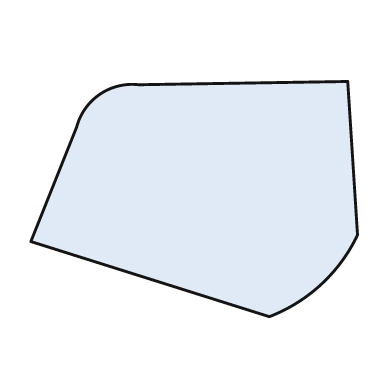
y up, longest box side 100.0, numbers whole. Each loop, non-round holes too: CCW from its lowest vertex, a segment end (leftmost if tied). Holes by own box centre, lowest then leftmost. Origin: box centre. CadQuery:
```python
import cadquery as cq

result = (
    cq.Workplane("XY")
    .moveTo(23.0, -36.0)
    .threePointArc((39.0, -26.0), (50.0, -11.0))
    .lineTo(47.0, 36.0)
    .lineTo(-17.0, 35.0)
    .threePointArc((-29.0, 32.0), (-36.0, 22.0))
    .lineTo(-50.0, -13.0)
    .close()
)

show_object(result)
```